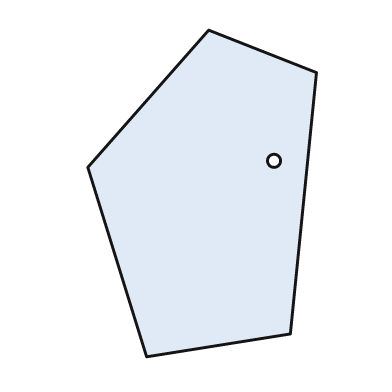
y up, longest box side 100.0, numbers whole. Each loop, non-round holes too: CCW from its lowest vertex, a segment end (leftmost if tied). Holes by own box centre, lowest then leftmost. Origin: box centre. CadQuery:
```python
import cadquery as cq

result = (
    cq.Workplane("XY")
    .moveTo(-17.0, -50.0)
    .lineTo(27.0, -43.0)
    .lineTo(35.0, 37.0)
    .lineTo(2.0, 50.0)
    .lineTo(-35.0, 8.0)
    .close()
    .moveTo(22.0, 10.0)
    .circle(2.0)
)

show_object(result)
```